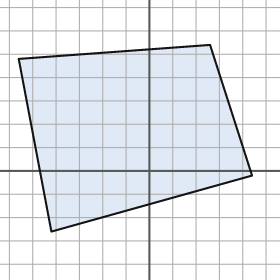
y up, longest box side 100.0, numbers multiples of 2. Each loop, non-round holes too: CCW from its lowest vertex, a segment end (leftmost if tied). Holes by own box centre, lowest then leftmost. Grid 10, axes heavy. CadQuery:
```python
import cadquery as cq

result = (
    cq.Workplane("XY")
    .moveTo(-42.0, -26.0)
    .lineTo(44.0, -2.0)
    .lineTo(26.0, 54.0)
    .lineTo(-56.0, 48.0)
    .close()
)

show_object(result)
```